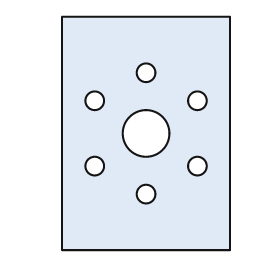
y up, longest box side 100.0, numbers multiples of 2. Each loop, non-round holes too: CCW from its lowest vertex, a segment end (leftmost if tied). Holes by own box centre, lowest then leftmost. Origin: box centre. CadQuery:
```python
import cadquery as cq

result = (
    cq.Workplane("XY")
    .moveTo(-36.0, -50.0)
    .lineTo(36.0, -50.0)
    .lineTo(36.0, 50.0)
    .lineTo(-36.0, 50.0)
    .close()
    .moveTo(0.0, -26.0)
    .circle(4.0)
    .moveTo(-22.0, -14.0)
    .circle(4.0)
    .moveTo(22.0, -14.0)
    .circle(4.0)
    .moveTo(0.0, 0.0)
    .circle(10.0)
    .moveTo(-22.0, 14.0)
    .circle(4.0)
    .moveTo(22.0, 14.0)
    .circle(4.0)
    .moveTo(0.0, 26.0)
    .circle(4.0)
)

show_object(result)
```